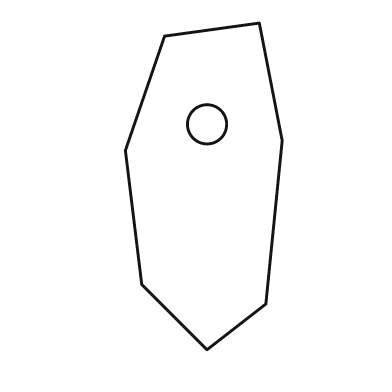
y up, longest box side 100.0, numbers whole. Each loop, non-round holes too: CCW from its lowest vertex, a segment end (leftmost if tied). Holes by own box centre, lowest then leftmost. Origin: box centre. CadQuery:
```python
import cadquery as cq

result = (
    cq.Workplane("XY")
    .moveTo(1.0, -50.0)
    .lineTo(19.0, -36.0)
    .lineTo(24.0, 14.0)
    .lineTo(17.0, 50.0)
    .lineTo(-12.0, 46.0)
    .lineTo(-24.0, 11.0)
    .lineTo(-19.0, -30.0)
    .close()
    .moveTo(1.0, 19.0)
    .circle(6.0)
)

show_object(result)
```